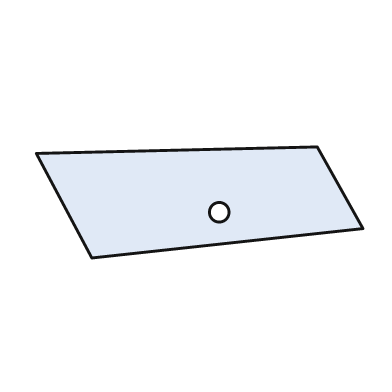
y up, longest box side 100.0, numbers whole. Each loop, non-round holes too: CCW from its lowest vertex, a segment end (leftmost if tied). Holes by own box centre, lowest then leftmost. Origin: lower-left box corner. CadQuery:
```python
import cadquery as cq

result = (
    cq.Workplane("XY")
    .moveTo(17.0, 0.0)
    .lineTo(100.0, 9.0)
    .lineTo(86.0, 34.0)
    .lineTo(0.0, 32.0)
    .close()
    .moveTo(56.0, 14.0)
    .circle(3.0)
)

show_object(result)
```